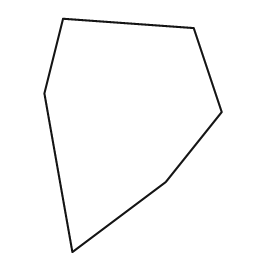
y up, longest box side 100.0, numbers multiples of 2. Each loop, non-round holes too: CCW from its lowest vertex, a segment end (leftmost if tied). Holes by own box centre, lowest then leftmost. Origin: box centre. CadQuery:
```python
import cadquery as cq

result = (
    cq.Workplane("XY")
    .moveTo(-26.0, -50.0)
    .lineTo(14.0, -20.0)
    .lineTo(38.0, 10.0)
    .lineTo(26.0, 46.0)
    .lineTo(-30.0, 50.0)
    .lineTo(-38.0, 18.0)
    .close()
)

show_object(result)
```